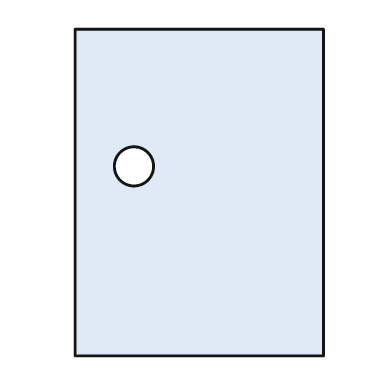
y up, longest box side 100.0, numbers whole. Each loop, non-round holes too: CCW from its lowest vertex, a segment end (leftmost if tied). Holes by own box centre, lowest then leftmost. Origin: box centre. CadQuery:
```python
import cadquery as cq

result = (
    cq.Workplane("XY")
    .moveTo(-38.0, -50.0)
    .lineTo(38.0, -50.0)
    .lineTo(38.0, 50.0)
    .lineTo(-38.0, 50.0)
    .close()
    .moveTo(-20.0, 8.0)
    .circle(6.0)
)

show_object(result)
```